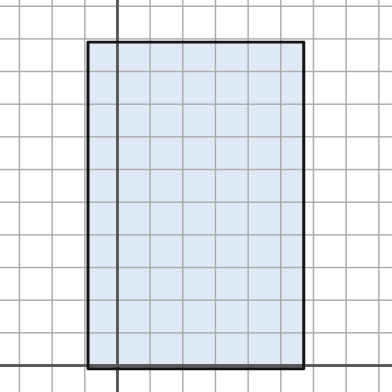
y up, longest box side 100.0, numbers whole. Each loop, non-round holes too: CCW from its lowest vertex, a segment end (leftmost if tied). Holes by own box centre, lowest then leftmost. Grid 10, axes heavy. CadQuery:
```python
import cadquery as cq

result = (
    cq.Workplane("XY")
    .moveTo(-9.0, -1.0)
    .lineTo(57.0, -1.0)
    .lineTo(57.0, 99.0)
    .lineTo(-9.0, 99.0)
    .close()
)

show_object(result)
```